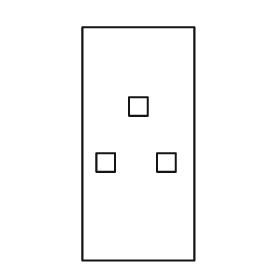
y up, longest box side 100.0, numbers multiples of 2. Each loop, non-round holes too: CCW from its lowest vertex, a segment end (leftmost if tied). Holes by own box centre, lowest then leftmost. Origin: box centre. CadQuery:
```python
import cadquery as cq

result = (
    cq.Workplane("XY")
    .moveTo(-24.0, -50.0)
    .lineTo(24.0, -50.0)
    .lineTo(24.0, 50.0)
    .lineTo(-24.0, 50.0)
    .close()
    .moveTo(-18.0, -12.0)
    .lineTo(-10.0, -12.0)
    .lineTo(-10.0, -4.0)
    .lineTo(-18.0, -4.0)
    .close()
    .moveTo(8.0, -12.0)
    .lineTo(16.0, -12.0)
    .lineTo(16.0, -4.0)
    .lineTo(8.0, -4.0)
    .close()
    .moveTo(-4.0, 12.0)
    .lineTo(4.0, 12.0)
    .lineTo(4.0, 20.0)
    .lineTo(-4.0, 20.0)
    .close()
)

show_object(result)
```